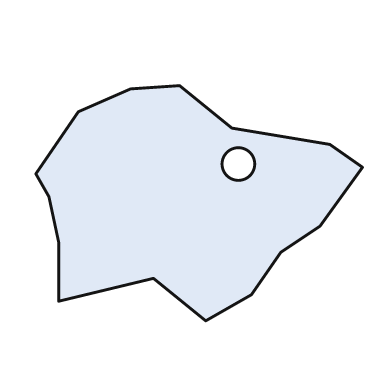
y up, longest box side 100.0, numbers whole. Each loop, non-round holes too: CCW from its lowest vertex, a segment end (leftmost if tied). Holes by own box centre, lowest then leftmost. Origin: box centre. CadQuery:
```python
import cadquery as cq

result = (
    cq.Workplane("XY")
    .moveTo(2.0, -36.0)
    .lineTo(16.0, -28.0)
    .lineTo(25.0, -15.0)
    .lineTo(37.0, -7.0)
    .lineTo(50.0, 11.0)
    .lineTo(40.0, 18.0)
    .lineTo(10.0, 23.0)
    .lineTo(-6.0, 36.0)
    .lineTo(-21.0, 35.0)
    .lineTo(-37.0, 28.0)
    .lineTo(-50.0, 9.0)
    .lineTo(-46.0, 2.0)
    .lineTo(-43.0, -12.0)
    .lineTo(-43.0, -30.0)
    .lineTo(-14.0, -23.0)
    .close()
    .moveTo(12.0, 12.0)
    .circle(5.0)
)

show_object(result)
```